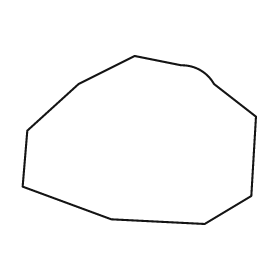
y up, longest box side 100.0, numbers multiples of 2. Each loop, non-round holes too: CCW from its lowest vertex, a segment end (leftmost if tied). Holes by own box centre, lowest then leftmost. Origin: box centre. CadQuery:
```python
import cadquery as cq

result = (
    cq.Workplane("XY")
    .moveTo(28.0, -36.0)
    .lineTo(48.0, -24.0)
    .lineTo(50.0, 10.0)
    .lineTo(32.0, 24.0)
    .threePointArc((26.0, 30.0), (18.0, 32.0))
    .lineTo(-2.0, 36.0)
    .lineTo(-26.0, 24.0)
    .lineTo(-48.0, 4.0)
    .lineTo(-50.0, -20.0)
    .lineTo(-12.0, -34.0)
    .close()
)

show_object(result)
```